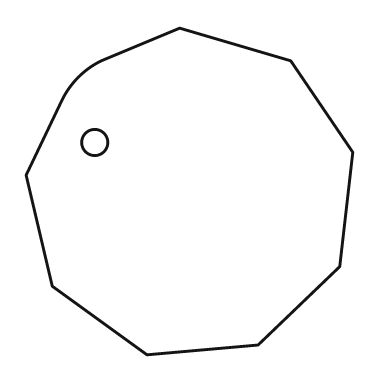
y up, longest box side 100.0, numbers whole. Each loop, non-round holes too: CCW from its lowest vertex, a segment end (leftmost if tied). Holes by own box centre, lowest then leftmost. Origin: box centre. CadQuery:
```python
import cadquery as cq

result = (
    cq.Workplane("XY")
    .moveTo(-13.0, -50.0)
    .lineTo(21.0, -47.0)
    .lineTo(46.0, -23.0)
    .lineTo(50.0, 12.0)
    .lineTo(31.0, 40.0)
    .lineTo(-3.0, 50.0)
    .lineTo(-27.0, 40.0)
    .threePointArc((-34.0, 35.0), (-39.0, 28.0))
    .lineTo(-50.0, 5.0)
    .lineTo(-42.0, -29.0)
    .close()
    .moveTo(-29.0, 15.0)
    .circle(4.0)
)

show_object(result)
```